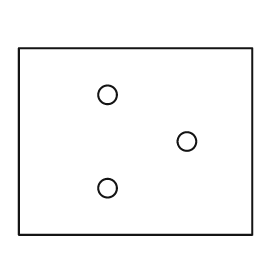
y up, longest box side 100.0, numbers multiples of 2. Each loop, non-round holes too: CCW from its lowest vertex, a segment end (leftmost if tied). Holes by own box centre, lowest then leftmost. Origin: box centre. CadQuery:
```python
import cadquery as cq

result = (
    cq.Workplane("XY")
    .moveTo(-50.0, -40.0)
    .lineTo(50.0, -40.0)
    .lineTo(50.0, 40.0)
    .lineTo(-50.0, 40.0)
    .close()
    .moveTo(-12.0, -20.0)
    .circle(4.0)
    .moveTo(22.0, 0.0)
    .circle(4.0)
    .moveTo(-12.0, 20.0)
    .circle(4.0)
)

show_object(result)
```